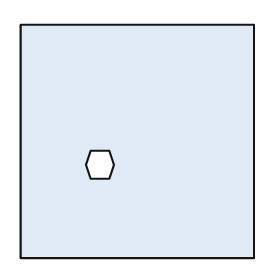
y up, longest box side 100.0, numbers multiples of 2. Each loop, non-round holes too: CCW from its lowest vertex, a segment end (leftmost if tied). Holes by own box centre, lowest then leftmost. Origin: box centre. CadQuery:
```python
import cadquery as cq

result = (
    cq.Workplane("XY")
    .moveTo(-50.0, -50.0)
    .lineTo(50.0, -50.0)
    .lineTo(50.0, 50.0)
    .lineTo(-50.0, 50.0)
    .close()
    .moveTo(-20.0, -16.0)
    .lineTo(-12.0, -16.0)
    .lineTo(-10.0, -10.0)
    .lineTo(-12.0, -4.0)
    .lineTo(-20.0, -4.0)
    .lineTo(-22.0, -10.0)
    .close()
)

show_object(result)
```